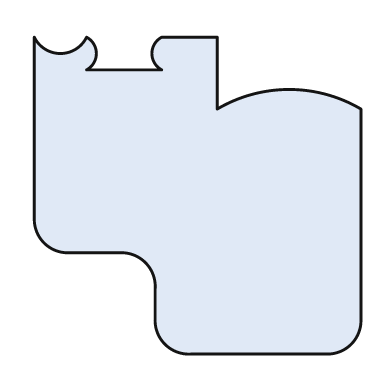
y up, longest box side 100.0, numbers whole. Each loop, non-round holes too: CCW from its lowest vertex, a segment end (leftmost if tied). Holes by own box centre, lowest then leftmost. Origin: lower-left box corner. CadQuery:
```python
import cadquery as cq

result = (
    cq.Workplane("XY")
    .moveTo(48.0, 0.0)
    .lineTo(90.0, 0.0)
    .threePointArc((97.0, 3.0), (100.0, 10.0))
    .lineTo(100.0, 75.0)
    .threePointArc((78.0, 81.0), (56.0, 75.0))
    .lineTo(56.0, 97.0)
    .lineTo(39.0, 97.0)
    .threePointArc((36.0, 92.0), (39.0, 87.0))
    .lineTo(16.0, 87.0)
    .threePointArc((19.0, 92.0), (16.0, 97.0))
    .threePointArc((8.0, 92.0), (0.0, 97.0))
    .lineTo(0.0, 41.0)
    .threePointArc((3.0, 34.0), (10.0, 31.0))
    .lineTo(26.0, 31.0)
    .threePointArc((34.0, 28.0), (37.0, 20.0))
    .lineTo(37.0, 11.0)
    .threePointArc((40.0, 3.0), (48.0, 0.0))
    .close()
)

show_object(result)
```